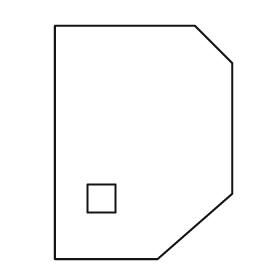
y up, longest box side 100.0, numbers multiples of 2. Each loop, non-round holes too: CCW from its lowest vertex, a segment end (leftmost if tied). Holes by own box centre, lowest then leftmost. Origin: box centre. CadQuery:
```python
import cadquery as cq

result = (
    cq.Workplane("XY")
    .moveTo(-38.0, -50.0)
    .lineTo(6.0, -50.0)
    .lineTo(38.0, -22.0)
    .lineTo(38.0, 34.0)
    .lineTo(22.0, 50.0)
    .lineTo(-38.0, 50.0)
    .close()
    .moveTo(-24.0, -30.0)
    .lineTo(-12.0, -30.0)
    .lineTo(-12.0, -18.0)
    .lineTo(-24.0, -18.0)
    .close()
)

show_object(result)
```